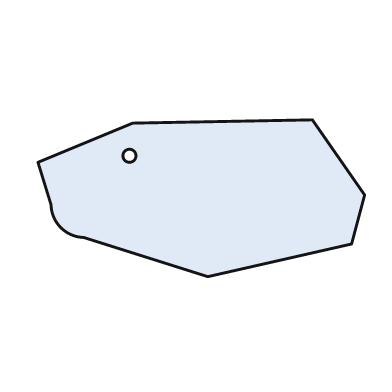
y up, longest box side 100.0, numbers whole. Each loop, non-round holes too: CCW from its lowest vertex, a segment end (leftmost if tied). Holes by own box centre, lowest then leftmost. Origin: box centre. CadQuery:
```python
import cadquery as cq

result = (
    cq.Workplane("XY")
    .moveTo(2.0, -24.0)
    .lineTo(46.0, -14.0)
    .lineTo(50.0, 1.0)
    .lineTo(34.0, 24.0)
    .lineTo(-21.0, 23.0)
    .lineTo(-50.0, 11.0)
    .lineTo(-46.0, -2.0)
    .threePointArc((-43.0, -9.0), (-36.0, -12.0))
    .close()
    .moveTo(-22.0, 13.0)
    .circle(2.0)
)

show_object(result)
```